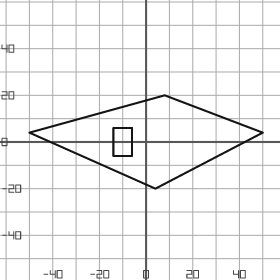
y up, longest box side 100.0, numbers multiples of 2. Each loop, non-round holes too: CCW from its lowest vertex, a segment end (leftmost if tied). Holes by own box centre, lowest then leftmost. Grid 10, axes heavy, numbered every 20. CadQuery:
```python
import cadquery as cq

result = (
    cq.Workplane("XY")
    .moveTo(4.0, -20.0)
    .lineTo(50.0, 4.0)
    .lineTo(8.0, 20.0)
    .lineTo(-50.0, 4.0)
    .close()
    .moveTo(-14.0, -6.0)
    .lineTo(-6.0, -6.0)
    .lineTo(-6.0, 6.0)
    .lineTo(-14.0, 6.0)
    .close()
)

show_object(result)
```